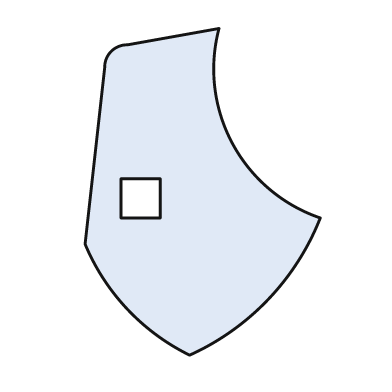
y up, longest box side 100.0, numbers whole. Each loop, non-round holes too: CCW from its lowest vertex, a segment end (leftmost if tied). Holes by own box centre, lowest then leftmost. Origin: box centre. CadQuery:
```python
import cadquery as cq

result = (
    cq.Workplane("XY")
    .moveTo(-4.0, -50.0)
    .threePointArc((20.0, -33.0), (36.0, -8.0))
    .threePointArc((9.0, 15.0), (5.0, 50.0))
    .lineTo(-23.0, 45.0)
    .threePointArc((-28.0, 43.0), (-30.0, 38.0))
    .lineTo(-36.0, -16.0)
    .threePointArc((-23.0, -36.0), (-4.0, -50.0))
    .close()
    .moveTo(-25.0, -8.0)
    .lineTo(-13.0, -8.0)
    .lineTo(-13.0, 4.0)
    .lineTo(-25.0, 4.0)
    .close()
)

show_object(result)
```